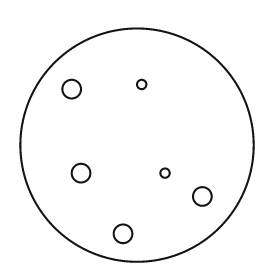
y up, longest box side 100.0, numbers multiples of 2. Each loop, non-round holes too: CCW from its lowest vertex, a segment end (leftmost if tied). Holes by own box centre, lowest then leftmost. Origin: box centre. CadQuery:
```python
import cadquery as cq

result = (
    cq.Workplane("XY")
    .moveTo(0.0, 0.0)
    .circle(50.0)
    .moveTo(-6.0, -38.0)
    .circle(4.0)
    .moveTo(28.0, -22.0)
    .circle(4.0)
    .moveTo(-24.0, -12.0)
    .circle(4.0)
    .moveTo(12.0, -12.0)
    .circle(2.0)
    .moveTo(-28.0, 24.0)
    .circle(4.0)
    .moveTo(2.0, 26.0)
    .circle(2.0)
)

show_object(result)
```